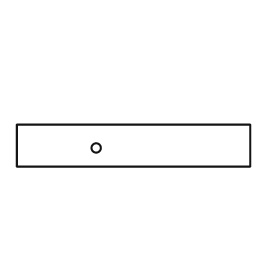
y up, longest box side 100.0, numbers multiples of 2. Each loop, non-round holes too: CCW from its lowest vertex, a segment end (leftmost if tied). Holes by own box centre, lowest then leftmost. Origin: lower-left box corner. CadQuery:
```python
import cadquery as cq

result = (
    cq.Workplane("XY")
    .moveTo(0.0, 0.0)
    .lineTo(100.0, 0.0)
    .lineTo(100.0, 18.0)
    .lineTo(0.0, 18.0)
    .close()
    .moveTo(34.0, 8.0)
    .circle(2.0)
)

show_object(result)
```